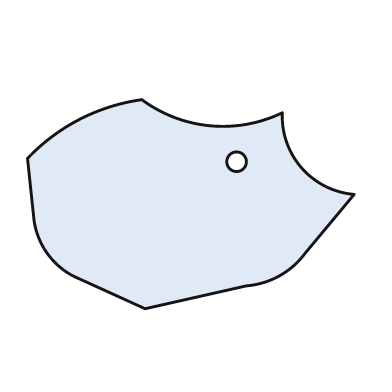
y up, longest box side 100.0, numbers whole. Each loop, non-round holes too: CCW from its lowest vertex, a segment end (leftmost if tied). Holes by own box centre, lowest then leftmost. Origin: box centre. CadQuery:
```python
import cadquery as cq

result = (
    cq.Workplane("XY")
    .moveTo(-14.0, -32.0)
    .lineTo(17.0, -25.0)
    .threePointArc((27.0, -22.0), (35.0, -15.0))
    .lineTo(50.0, 3.0)
    .threePointArc((34.0, 11.0), (28.0, 28.0))
    .threePointArc((6.0, 24.0), (-15.0, 32.0))
    .threePointArc((-34.0, 26.0), (-50.0, 14.0))
    .lineTo(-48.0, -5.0)
    .threePointArc((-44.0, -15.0), (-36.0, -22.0))
    .close()
    .moveTo(14.0, 13.0)
    .circle(3.0)
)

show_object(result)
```